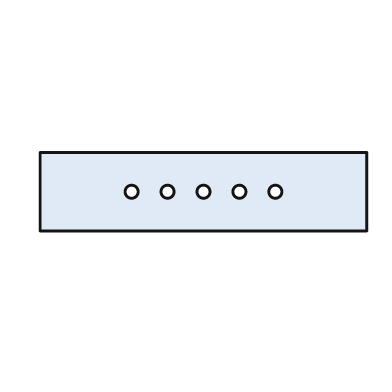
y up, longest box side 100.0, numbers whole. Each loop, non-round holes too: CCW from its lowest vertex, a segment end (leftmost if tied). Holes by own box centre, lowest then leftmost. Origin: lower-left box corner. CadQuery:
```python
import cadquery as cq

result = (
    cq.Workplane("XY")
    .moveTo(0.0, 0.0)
    .lineTo(100.0, 0.0)
    .lineTo(100.0, 24.0)
    .lineTo(0.0, 24.0)
    .close()
    .moveTo(28.0, 12.0)
    .circle(2.0)
    .moveTo(39.0, 12.0)
    .circle(2.0)
    .moveTo(50.0, 12.0)
    .circle(2.0)
    .moveTo(61.0, 12.0)
    .circle(2.0)
    .moveTo(72.0, 12.0)
    .circle(2.0)
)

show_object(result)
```